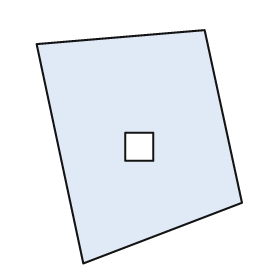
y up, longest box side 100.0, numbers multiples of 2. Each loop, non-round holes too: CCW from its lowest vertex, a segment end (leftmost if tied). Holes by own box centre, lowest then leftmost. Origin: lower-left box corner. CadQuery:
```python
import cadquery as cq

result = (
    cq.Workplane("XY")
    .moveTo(20.0, 0.0)
    .lineTo(88.0, 26.0)
    .lineTo(72.0, 100.0)
    .lineTo(0.0, 94.0)
    .close()
    .moveTo(38.0, 44.0)
    .lineTo(50.0, 44.0)
    .lineTo(50.0, 56.0)
    .lineTo(38.0, 56.0)
    .close()
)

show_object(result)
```